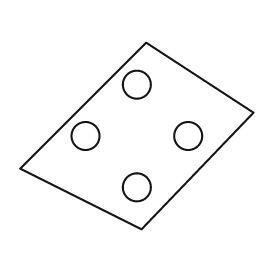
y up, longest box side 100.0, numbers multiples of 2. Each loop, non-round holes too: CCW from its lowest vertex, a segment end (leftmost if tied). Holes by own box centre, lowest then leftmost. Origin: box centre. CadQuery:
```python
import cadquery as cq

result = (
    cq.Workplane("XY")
    .moveTo(2.0, -40.0)
    .lineTo(50.0, 10.0)
    .lineTo(4.0, 40.0)
    .lineTo(-50.0, -14.0)
    .close()
    .moveTo(0.0, -22.0)
    .circle(6.0)
    .moveTo(-22.0, 0.0)
    .circle(6.0)
    .moveTo(22.0, 0.0)
    .circle(6.0)
    .moveTo(0.0, 22.0)
    .circle(6.0)
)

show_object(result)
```